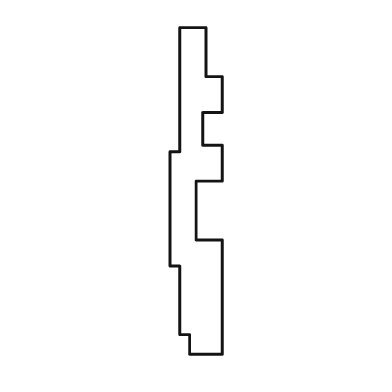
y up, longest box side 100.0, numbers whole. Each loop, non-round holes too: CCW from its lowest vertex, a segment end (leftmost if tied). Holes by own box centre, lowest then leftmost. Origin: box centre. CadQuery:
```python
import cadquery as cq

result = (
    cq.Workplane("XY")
    .moveTo(-2.0, -50.0)
    .lineTo(8.0, -50.0)
    .lineTo(8.0, -15.0)
    .lineTo(0.0, -15.0)
    .lineTo(0.0, 3.0)
    .lineTo(8.0, 3.0)
    .lineTo(8.0, 14.0)
    .lineTo(2.0, 14.0)
    .lineTo(2.0, 24.0)
    .lineTo(8.0, 24.0)
    .lineTo(8.0, 35.0)
    .lineTo(3.0, 35.0)
    .lineTo(3.0, 50.0)
    .lineTo(-5.0, 50.0)
    .lineTo(-5.0, 12.0)
    .lineTo(-8.0, 12.0)
    .lineTo(-8.0, -23.0)
    .lineTo(-5.0, -23.0)
    .lineTo(-5.0, -44.0)
    .lineTo(-2.0, -44.0)
    .close()
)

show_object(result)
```